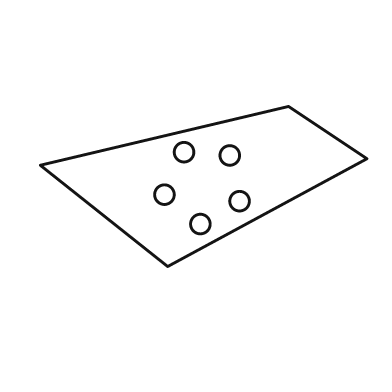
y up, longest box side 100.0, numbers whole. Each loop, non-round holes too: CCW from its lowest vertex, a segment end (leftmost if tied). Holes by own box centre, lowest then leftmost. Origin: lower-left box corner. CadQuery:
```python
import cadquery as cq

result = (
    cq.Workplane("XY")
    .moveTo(39.0, 0.0)
    .lineTo(100.0, 33.0)
    .lineTo(76.0, 49.0)
    .lineTo(0.0, 31.0)
    .close()
    .moveTo(49.0, 13.0)
    .circle(3.0)
    .moveTo(61.0, 20.0)
    .circle(3.0)
    .moveTo(38.0, 22.0)
    .circle(3.0)
    .moveTo(58.0, 34.0)
    .circle(3.0)
    .moveTo(44.0, 35.0)
    .circle(3.0)
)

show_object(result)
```